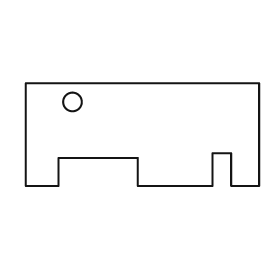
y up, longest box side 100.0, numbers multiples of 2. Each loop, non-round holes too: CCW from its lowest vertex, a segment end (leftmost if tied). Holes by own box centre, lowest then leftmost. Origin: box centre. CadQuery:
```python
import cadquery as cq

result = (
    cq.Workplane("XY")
    .moveTo(-50.0, -22.0)
    .lineTo(-36.0, -22.0)
    .lineTo(-36.0, -10.0)
    .lineTo(-2.0, -10.0)
    .lineTo(-2.0, -22.0)
    .lineTo(30.0, -22.0)
    .lineTo(30.0, -8.0)
    .lineTo(38.0, -8.0)
    .lineTo(38.0, -22.0)
    .lineTo(50.0, -22.0)
    .lineTo(50.0, 22.0)
    .lineTo(-50.0, 22.0)
    .close()
    .moveTo(-30.0, 14.0)
    .circle(4.0)
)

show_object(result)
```